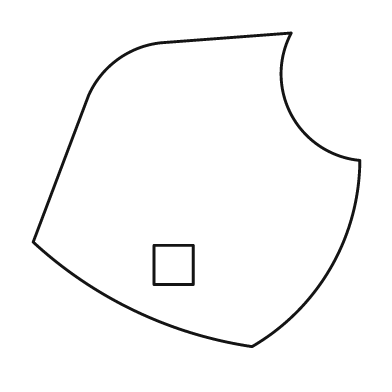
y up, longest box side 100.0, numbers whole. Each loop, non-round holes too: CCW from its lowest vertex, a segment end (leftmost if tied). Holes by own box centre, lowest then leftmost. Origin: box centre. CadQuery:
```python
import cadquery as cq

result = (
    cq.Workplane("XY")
    .moveTo(17.0, -48.0)
    .threePointArc((41.0, -24.0), (50.0, 9.0))
    .threePointArc((29.0, 23.0), (29.0, 48.0))
    .lineTo(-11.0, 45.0)
    .threePointArc((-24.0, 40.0), (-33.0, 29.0))
    .lineTo(-50.0, -16.0)
    .threePointArc((-19.0, -37.0), (17.0, -48.0))
    .close()
    .moveTo(-13.0, -29.0)
    .lineTo(-1.0, -29.0)
    .lineTo(-1.0, -17.0)
    .lineTo(-13.0, -17.0)
    .close()
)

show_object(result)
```